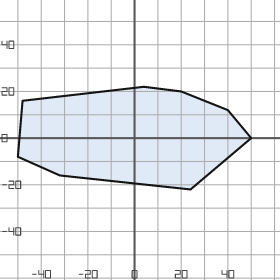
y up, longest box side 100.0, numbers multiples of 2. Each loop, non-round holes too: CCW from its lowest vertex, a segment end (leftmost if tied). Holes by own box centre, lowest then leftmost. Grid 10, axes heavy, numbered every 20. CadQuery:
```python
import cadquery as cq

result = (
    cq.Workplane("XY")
    .moveTo(24.0, -22.0)
    .lineTo(50.0, 0.0)
    .lineTo(40.0, 12.0)
    .lineTo(20.0, 20.0)
    .lineTo(4.0, 22.0)
    .lineTo(-48.0, 16.0)
    .lineTo(-50.0, -8.0)
    .lineTo(-32.0, -16.0)
    .close()
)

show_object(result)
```